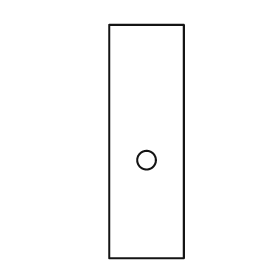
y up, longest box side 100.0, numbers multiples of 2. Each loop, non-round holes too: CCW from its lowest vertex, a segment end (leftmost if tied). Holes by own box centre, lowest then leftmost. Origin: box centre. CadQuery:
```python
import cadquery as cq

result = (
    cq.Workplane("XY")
    .moveTo(-16.0, -50.0)
    .lineTo(16.0, -50.0)
    .lineTo(16.0, 50.0)
    .lineTo(-16.0, 50.0)
    .close()
    .moveTo(0.0, -8.0)
    .circle(4.0)
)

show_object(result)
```